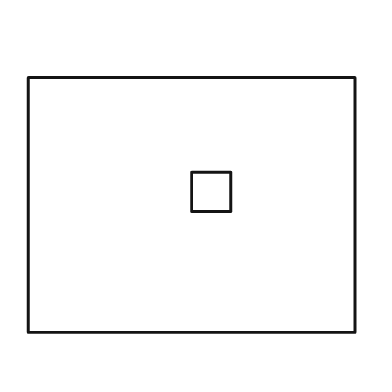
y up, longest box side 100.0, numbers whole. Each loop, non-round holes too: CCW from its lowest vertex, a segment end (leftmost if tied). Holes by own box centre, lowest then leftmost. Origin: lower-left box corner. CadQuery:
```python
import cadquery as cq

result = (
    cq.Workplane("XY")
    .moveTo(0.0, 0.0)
    .lineTo(100.0, 0.0)
    .lineTo(100.0, 78.0)
    .lineTo(0.0, 78.0)
    .close()
    .moveTo(50.0, 37.0)
    .lineTo(62.0, 37.0)
    .lineTo(62.0, 49.0)
    .lineTo(50.0, 49.0)
    .close()
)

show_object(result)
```